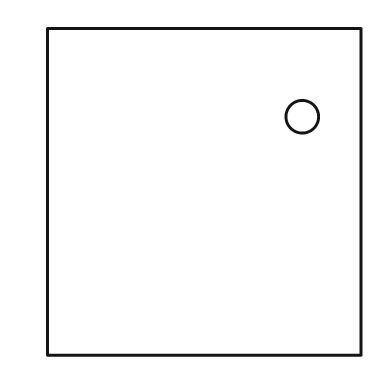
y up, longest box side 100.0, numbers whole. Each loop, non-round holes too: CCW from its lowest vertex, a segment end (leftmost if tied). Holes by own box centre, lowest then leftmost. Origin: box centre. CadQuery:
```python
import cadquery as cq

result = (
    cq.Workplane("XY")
    .moveTo(-48.0, -50.0)
    .lineTo(48.0, -50.0)
    .lineTo(48.0, 50.0)
    .lineTo(-48.0, 50.0)
    .close()
    .moveTo(30.0, 23.0)
    .circle(5.0)
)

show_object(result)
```